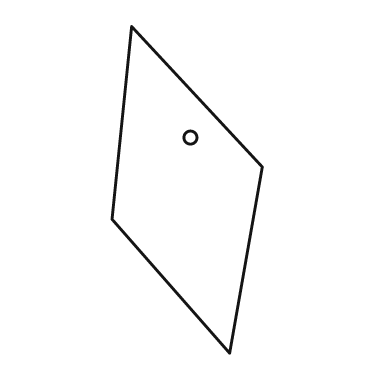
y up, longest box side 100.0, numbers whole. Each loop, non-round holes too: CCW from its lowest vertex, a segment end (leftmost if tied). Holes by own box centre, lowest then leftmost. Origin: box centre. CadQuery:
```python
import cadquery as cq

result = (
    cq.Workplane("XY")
    .moveTo(13.0, -50.0)
    .lineTo(23.0, 7.0)
    .lineTo(-17.0, 50.0)
    .lineTo(-23.0, -9.0)
    .close()
    .moveTo(1.0, 16.0)
    .circle(2.0)
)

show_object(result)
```